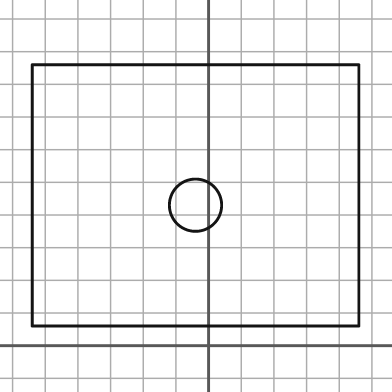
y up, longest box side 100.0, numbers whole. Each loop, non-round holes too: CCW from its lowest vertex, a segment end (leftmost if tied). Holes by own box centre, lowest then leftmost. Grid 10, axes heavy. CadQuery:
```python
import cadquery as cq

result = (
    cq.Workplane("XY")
    .moveTo(-54.0, 6.0)
    .lineTo(46.0, 6.0)
    .lineTo(46.0, 86.0)
    .lineTo(-54.0, 86.0)
    .close()
    .moveTo(-4.0, 43.0)
    .circle(8.0)
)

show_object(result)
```